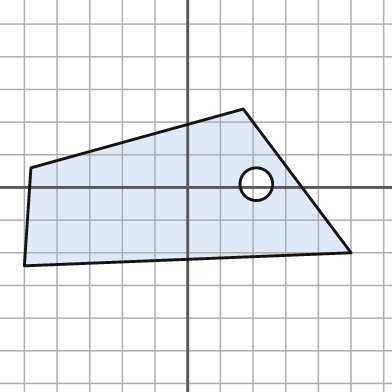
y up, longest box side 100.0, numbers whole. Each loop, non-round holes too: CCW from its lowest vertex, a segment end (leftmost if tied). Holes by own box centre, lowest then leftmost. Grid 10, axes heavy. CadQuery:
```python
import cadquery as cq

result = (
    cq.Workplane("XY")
    .moveTo(-50.0, -24.0)
    .lineTo(50.0, -20.0)
    .lineTo(17.0, 24.0)
    .lineTo(-48.0, 6.0)
    .close()
    .moveTo(21.0, 1.0)
    .circle(5.0)
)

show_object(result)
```